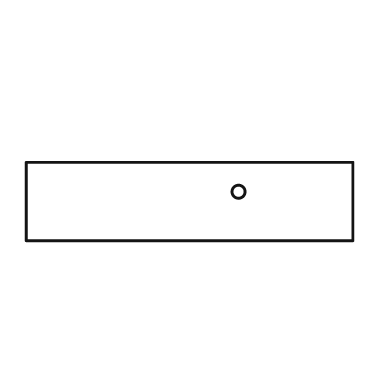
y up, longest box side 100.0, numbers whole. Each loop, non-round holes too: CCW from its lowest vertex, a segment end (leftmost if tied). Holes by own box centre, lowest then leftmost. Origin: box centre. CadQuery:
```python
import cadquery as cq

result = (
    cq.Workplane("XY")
    .moveTo(-50.0, -12.0)
    .lineTo(50.0, -12.0)
    .lineTo(50.0, 12.0)
    .lineTo(-50.0, 12.0)
    .close()
    .moveTo(15.0, 3.0)
    .circle(2.0)
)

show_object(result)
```